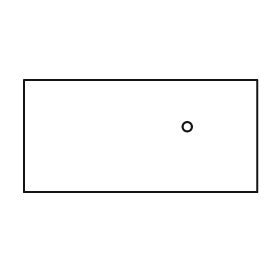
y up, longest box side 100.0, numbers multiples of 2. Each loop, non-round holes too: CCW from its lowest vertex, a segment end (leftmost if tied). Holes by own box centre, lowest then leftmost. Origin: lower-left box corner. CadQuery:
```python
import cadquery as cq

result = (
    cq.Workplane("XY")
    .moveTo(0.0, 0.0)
    .lineTo(100.0, 0.0)
    .lineTo(100.0, 48.0)
    .lineTo(0.0, 48.0)
    .close()
    .moveTo(70.0, 28.0)
    .circle(2.0)
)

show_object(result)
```